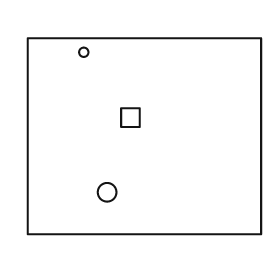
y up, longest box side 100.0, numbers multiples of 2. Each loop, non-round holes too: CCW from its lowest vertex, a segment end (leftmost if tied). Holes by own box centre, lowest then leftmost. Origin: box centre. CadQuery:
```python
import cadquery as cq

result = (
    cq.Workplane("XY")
    .moveTo(-50.0, -42.0)
    .lineTo(50.0, -42.0)
    .lineTo(50.0, 42.0)
    .lineTo(-50.0, 42.0)
    .close()
    .moveTo(-16.0, -24.0)
    .circle(4.0)
    .moveTo(-10.0, 4.0)
    .lineTo(-2.0, 4.0)
    .lineTo(-2.0, 12.0)
    .lineTo(-10.0, 12.0)
    .close()
    .moveTo(-26.0, 36.0)
    .circle(2.0)
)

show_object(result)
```